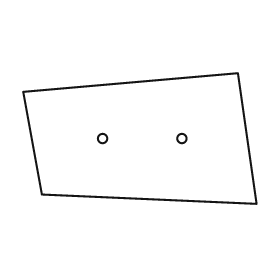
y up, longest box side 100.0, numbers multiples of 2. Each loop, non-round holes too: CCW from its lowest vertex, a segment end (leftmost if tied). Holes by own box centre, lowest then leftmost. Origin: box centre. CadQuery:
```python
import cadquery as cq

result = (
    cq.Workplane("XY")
    .moveTo(50.0, -28.0)
    .lineTo(42.0, 28.0)
    .lineTo(-50.0, 20.0)
    .lineTo(-42.0, -24.0)
    .close()
    .moveTo(-16.0, 0.0)
    .circle(2.0)
    .moveTo(18.0, 0.0)
    .circle(2.0)
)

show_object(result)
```